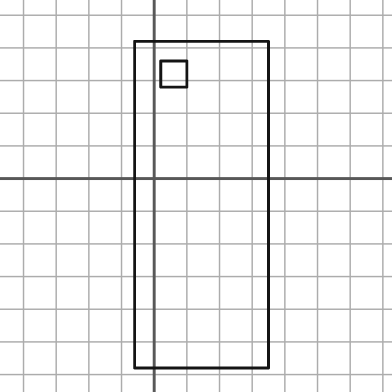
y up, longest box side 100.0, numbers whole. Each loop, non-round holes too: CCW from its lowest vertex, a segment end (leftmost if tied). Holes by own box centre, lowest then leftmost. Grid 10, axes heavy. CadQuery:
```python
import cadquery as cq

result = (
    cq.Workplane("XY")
    .moveTo(-6.0, -58.0)
    .lineTo(35.0, -58.0)
    .lineTo(35.0, 42.0)
    .lineTo(-6.0, 42.0)
    .close()
    .moveTo(2.0, 28.0)
    .lineTo(10.0, 28.0)
    .lineTo(10.0, 36.0)
    .lineTo(2.0, 36.0)
    .close()
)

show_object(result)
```